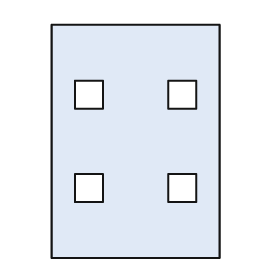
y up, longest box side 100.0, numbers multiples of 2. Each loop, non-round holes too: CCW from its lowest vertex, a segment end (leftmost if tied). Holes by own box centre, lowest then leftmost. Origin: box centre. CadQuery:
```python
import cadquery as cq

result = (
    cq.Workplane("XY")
    .moveTo(-36.0, -50.0)
    .lineTo(36.0, -50.0)
    .lineTo(36.0, 50.0)
    .lineTo(-36.0, 50.0)
    .close()
    .moveTo(-26.0, -26.0)
    .lineTo(-14.0, -26.0)
    .lineTo(-14.0, -14.0)
    .lineTo(-26.0, -14.0)
    .close()
    .moveTo(14.0, -26.0)
    .lineTo(26.0, -26.0)
    .lineTo(26.0, -14.0)
    .lineTo(14.0, -14.0)
    .close()
    .moveTo(-26.0, 14.0)
    .lineTo(-14.0, 14.0)
    .lineTo(-14.0, 26.0)
    .lineTo(-26.0, 26.0)
    .close()
    .moveTo(14.0, 14.0)
    .lineTo(26.0, 14.0)
    .lineTo(26.0, 26.0)
    .lineTo(14.0, 26.0)
    .close()
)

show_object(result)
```